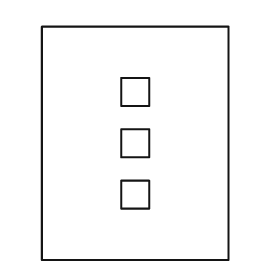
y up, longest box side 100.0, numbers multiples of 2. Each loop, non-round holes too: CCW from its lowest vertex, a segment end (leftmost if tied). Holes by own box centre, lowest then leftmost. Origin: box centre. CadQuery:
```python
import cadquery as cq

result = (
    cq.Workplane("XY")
    .moveTo(-40.0, -50.0)
    .lineTo(40.0, -50.0)
    .lineTo(40.0, 50.0)
    .lineTo(-40.0, 50.0)
    .close()
    .moveTo(-6.0, -28.0)
    .lineTo(6.0, -28.0)
    .lineTo(6.0, -16.0)
    .lineTo(-6.0, -16.0)
    .close()
    .moveTo(-6.0, -6.0)
    .lineTo(6.0, -6.0)
    .lineTo(6.0, 6.0)
    .lineTo(-6.0, 6.0)
    .close()
    .moveTo(-6.0, 16.0)
    .lineTo(6.0, 16.0)
    .lineTo(6.0, 28.0)
    .lineTo(-6.0, 28.0)
    .close()
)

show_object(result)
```